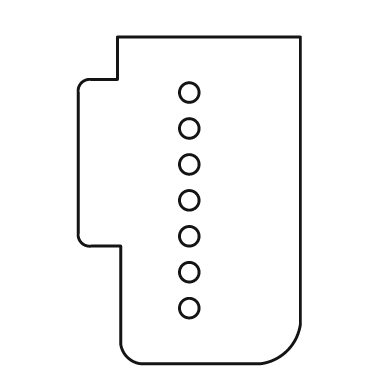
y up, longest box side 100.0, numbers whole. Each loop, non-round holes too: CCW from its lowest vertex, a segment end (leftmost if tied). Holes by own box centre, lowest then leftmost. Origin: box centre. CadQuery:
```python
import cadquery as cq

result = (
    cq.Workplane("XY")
    .moveTo(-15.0, -50.0)
    .lineTo(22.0, -50.0)
    .threePointArc((30.0, -46.0), (34.0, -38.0))
    .lineTo(34.0, 50.0)
    .lineTo(-22.0, 50.0)
    .lineTo(-22.0, 37.0)
    .lineTo(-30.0, 37.0)
    .threePointArc((-33.0, 36.0), (-34.0, 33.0))
    .lineTo(-34.0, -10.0)
    .threePointArc((-33.0, -13.0), (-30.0, -14.0))
    .lineTo(-21.0, -14.0)
    .lineTo(-21.0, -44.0)
    .threePointArc((-19.0, -48.0), (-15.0, -50.0))
    .close()
    .moveTo(0.0, -33.0)
    .circle(3.0)
    .moveTo(0.0, -22.0)
    .circle(3.0)
    .moveTo(0.0, -11.0)
    .circle(3.0)
    .moveTo(0.0, 0.0)
    .circle(3.0)
    .moveTo(0.0, 11.0)
    .circle(3.0)
    .moveTo(0.0, 22.0)
    .circle(3.0)
    .moveTo(0.0, 33.0)
    .circle(3.0)
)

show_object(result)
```